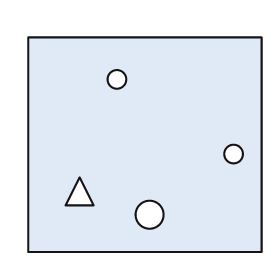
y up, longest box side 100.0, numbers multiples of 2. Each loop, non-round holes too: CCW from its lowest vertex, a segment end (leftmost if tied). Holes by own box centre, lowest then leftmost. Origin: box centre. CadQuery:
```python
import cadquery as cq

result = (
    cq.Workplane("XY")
    .moveTo(-50.0, -46.0)
    .lineTo(50.0, -46.0)
    .lineTo(50.0, 46.0)
    .lineTo(-50.0, 46.0)
    .close()
    .moveTo(2.0, -30.0)
    .circle(6.0)
    .moveTo(-34.0, -26.0)
    .lineTo(-22.0, -26.0)
    .lineTo(-28.0, -14.0)
    .close()
    .moveTo(38.0, -4.0)
    .circle(4.0)
    .moveTo(-12.0, 28.0)
    .circle(4.0)
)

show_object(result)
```